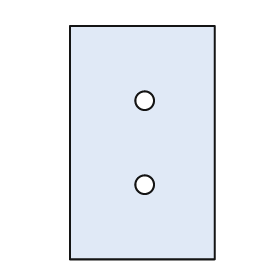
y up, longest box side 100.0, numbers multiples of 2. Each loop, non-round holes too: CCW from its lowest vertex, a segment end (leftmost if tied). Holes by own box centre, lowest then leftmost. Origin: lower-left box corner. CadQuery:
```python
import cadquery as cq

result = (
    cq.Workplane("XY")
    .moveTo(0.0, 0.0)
    .lineTo(62.0, 0.0)
    .lineTo(62.0, 100.0)
    .lineTo(0.0, 100.0)
    .close()
    .moveTo(32.0, 32.0)
    .circle(4.0)
    .moveTo(32.0, 68.0)
    .circle(4.0)
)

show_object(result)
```